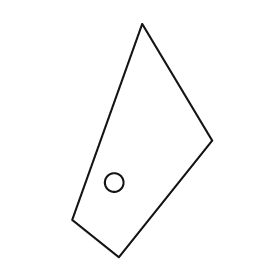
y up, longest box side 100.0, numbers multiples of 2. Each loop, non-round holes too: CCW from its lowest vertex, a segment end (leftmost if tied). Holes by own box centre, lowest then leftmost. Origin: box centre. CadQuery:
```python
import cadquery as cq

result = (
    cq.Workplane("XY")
    .moveTo(-10.0, -50.0)
    .lineTo(30.0, 0.0)
    .lineTo(0.0, 50.0)
    .lineTo(-30.0, -34.0)
    .close()
    .moveTo(-12.0, -18.0)
    .circle(4.0)
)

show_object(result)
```